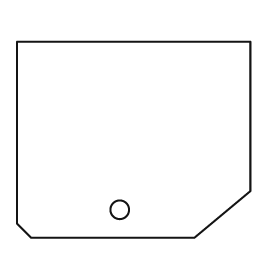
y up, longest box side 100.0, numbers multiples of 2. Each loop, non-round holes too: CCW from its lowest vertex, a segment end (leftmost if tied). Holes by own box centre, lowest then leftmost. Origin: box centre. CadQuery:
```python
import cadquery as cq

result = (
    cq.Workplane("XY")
    .moveTo(-44.0, -42.0)
    .lineTo(26.0, -42.0)
    .lineTo(50.0, -22.0)
    .lineTo(50.0, 42.0)
    .lineTo(-50.0, 42.0)
    .lineTo(-50.0, -36.0)
    .close()
    .moveTo(-6.0, -30.0)
    .circle(4.0)
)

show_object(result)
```